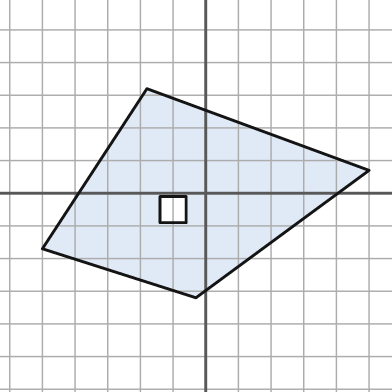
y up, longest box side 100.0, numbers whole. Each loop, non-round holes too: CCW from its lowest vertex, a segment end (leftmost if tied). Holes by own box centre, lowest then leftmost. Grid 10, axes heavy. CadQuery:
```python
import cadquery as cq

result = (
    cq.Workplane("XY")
    .moveTo(-3.0, -32.0)
    .lineTo(50.0, 7.0)
    .lineTo(-18.0, 32.0)
    .lineTo(-50.0, -17.0)
    .close()
    .moveTo(-14.0, -9.0)
    .lineTo(-6.0, -9.0)
    .lineTo(-6.0, -1.0)
    .lineTo(-14.0, -1.0)
    .close()
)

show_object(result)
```